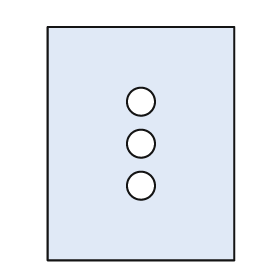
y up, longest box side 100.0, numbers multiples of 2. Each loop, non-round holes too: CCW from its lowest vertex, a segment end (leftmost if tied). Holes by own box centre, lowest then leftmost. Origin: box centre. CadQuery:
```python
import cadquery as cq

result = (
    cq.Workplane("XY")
    .moveTo(-40.0, -50.0)
    .lineTo(40.0, -50.0)
    .lineTo(40.0, 50.0)
    .lineTo(-40.0, 50.0)
    .close()
    .moveTo(0.0, -18.0)
    .circle(6.0)
    .moveTo(0.0, 0.0)
    .circle(6.0)
    .moveTo(0.0, 18.0)
    .circle(6.0)
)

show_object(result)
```